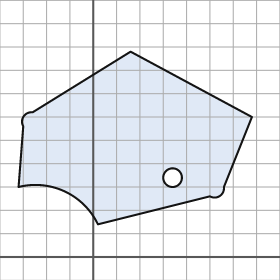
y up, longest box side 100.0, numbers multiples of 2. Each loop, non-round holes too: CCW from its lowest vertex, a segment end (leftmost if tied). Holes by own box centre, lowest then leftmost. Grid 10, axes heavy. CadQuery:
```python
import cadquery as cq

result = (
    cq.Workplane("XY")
    .moveTo(2.0, 14.0)
    .lineTo(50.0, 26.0)
    .threePointArc((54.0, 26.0), (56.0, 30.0))
    .lineTo(68.0, 60.0)
    .lineTo(16.0, 88.0)
    .lineTo(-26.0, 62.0)
    .threePointArc((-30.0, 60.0), (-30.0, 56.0))
    .lineTo(-32.0, 30.0)
    .threePointArc((-12.0, 28.0), (2.0, 14.0))
    .close()
    .moveTo(34.0, 34.0)
    .circle(4.0)
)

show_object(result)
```